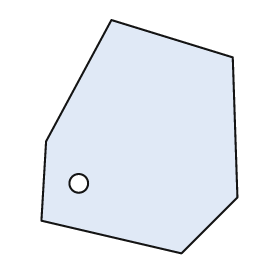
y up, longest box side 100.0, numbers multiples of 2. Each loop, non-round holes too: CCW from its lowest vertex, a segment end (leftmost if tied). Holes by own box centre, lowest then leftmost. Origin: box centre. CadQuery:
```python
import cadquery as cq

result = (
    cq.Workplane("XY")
    .moveTo(18.0, -50.0)
    .lineTo(42.0, -26.0)
    .lineTo(40.0, 34.0)
    .lineTo(-12.0, 50.0)
    .lineTo(-40.0, -2.0)
    .lineTo(-42.0, -36.0)
    .close()
    .moveTo(-26.0, -20.0)
    .circle(4.0)
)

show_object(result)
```